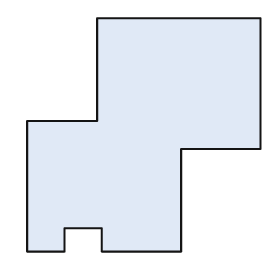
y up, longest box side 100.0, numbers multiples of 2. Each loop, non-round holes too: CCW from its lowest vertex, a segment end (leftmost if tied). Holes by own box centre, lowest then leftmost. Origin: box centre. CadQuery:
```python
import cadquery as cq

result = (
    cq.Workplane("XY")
    .moveTo(-50.0, -50.0)
    .lineTo(-34.0, -50.0)
    .lineTo(-34.0, -40.0)
    .lineTo(-18.0, -40.0)
    .lineTo(-18.0, -50.0)
    .lineTo(16.0, -50.0)
    .lineTo(16.0, -6.0)
    .lineTo(50.0, -6.0)
    .lineTo(50.0, 50.0)
    .lineTo(-20.0, 50.0)
    .lineTo(-20.0, 6.0)
    .lineTo(-50.0, 6.0)
    .close()
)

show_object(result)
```